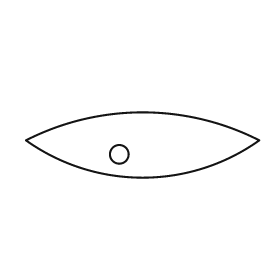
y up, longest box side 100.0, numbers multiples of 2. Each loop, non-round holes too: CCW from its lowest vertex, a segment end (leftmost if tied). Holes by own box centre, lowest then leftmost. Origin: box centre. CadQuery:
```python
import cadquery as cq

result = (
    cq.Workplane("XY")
    .moveTo(-50.0, 2.0)
    .threePointArc((0.0, -14.0), (50.0, 2.0))
    .threePointArc((0.0, 14.0), (-50.0, 2.0))
    .close()
    .moveTo(-10.0, -4.0)
    .circle(4.0)
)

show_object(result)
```